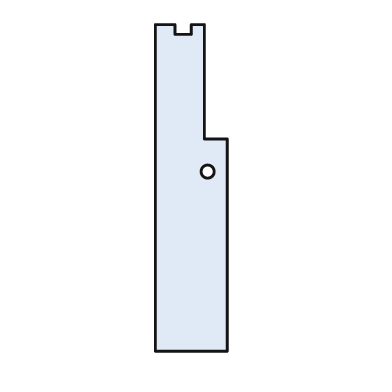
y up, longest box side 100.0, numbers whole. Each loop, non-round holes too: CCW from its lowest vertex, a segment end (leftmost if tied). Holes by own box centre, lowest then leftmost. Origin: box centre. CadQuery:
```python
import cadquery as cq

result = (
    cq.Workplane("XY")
    .moveTo(-11.0, -50.0)
    .lineTo(11.0, -50.0)
    .lineTo(11.0, 15.0)
    .lineTo(4.0, 15.0)
    .lineTo(4.0, 50.0)
    .lineTo(0.0, 50.0)
    .lineTo(0.0, 47.0)
    .lineTo(-5.0, 47.0)
    .lineTo(-5.0, 50.0)
    .lineTo(-11.0, 50.0)
    .close()
    .moveTo(5.0, 5.0)
    .circle(2.0)
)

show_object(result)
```